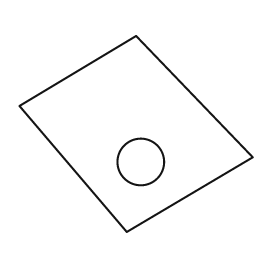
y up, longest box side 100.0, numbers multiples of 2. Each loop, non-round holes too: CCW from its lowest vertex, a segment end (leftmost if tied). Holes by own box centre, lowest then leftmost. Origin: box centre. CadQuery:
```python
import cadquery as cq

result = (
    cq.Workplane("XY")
    .moveTo(-4.0, -42.0)
    .lineTo(50.0, -10.0)
    .lineTo(0.0, 42.0)
    .lineTo(-50.0, 12.0)
    .close()
    .moveTo(2.0, -12.0)
    .circle(10.0)
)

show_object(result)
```